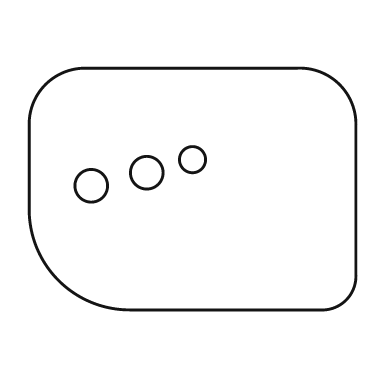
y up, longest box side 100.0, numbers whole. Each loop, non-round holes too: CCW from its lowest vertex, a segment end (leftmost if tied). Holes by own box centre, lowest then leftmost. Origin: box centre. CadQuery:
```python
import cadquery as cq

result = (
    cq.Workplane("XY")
    .moveTo(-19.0, -37.0)
    .lineTo(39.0, -37.0)
    .threePointArc((47.0, -34.0), (50.0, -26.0))
    .lineTo(50.0, 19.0)
    .threePointArc((45.0, 32.0), (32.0, 37.0))
    .lineTo(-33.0, 37.0)
    .threePointArc((-45.0, 32.0), (-50.0, 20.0))
    .lineTo(-50.0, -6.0)
    .threePointArc((-41.0, -28.0), (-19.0, -37.0))
    .close()
    .moveTo(-31.0, 1.0)
    .circle(5.0)
    .moveTo(-14.0, 5.0)
    .circle(5.0)
    .moveTo(0.0, 9.0)
    .circle(4.0)
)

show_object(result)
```